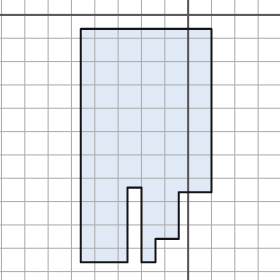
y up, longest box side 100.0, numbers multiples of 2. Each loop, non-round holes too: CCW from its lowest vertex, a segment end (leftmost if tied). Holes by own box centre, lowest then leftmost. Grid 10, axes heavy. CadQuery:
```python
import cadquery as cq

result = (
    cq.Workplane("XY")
    .moveTo(-46.0, -106.0)
    .lineTo(-26.0, -106.0)
    .lineTo(-26.0, -74.0)
    .lineTo(-20.0, -74.0)
    .lineTo(-20.0, -106.0)
    .lineTo(-14.0, -106.0)
    .lineTo(-14.0, -96.0)
    .lineTo(-4.0, -96.0)
    .lineTo(-4.0, -76.0)
    .lineTo(10.0, -76.0)
    .lineTo(10.0, -6.0)
    .lineTo(-46.0, -6.0)
    .close()
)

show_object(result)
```